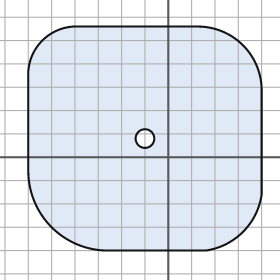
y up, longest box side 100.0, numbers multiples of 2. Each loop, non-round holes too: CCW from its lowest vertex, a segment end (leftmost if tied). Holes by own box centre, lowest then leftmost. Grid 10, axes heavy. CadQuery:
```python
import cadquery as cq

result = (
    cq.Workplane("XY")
    .moveTo(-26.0, -40.0)
    .lineTo(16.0, -40.0)
    .threePointArc((32.0, -32.0), (40.0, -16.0))
    .lineTo(40.0, 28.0)
    .threePointArc((32.0, 48.0), (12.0, 56.0))
    .lineTo(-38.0, 56.0)
    .threePointArc((-54.0, 50.0), (-60.0, 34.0))
    .lineTo(-60.0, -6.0)
    .threePointArc((-50.0, -30.0), (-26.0, -40.0))
    .close()
    .moveTo(-10.0, 8.0)
    .circle(4.0)
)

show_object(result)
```